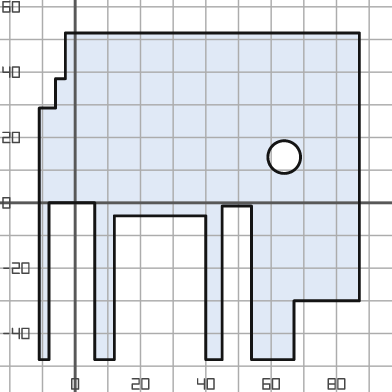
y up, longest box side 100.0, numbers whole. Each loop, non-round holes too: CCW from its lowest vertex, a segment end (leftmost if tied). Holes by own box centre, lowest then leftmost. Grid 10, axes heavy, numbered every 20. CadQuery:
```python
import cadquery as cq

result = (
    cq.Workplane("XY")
    .moveTo(-11.0, -48.0)
    .lineTo(-8.0, -48.0)
    .lineTo(-8.0, 0.0)
    .lineTo(6.0, 0.0)
    .lineTo(6.0, -48.0)
    .lineTo(12.0, -48.0)
    .lineTo(12.0, -4.0)
    .lineTo(40.0, -4.0)
    .lineTo(40.0, -48.0)
    .lineTo(45.0, -48.0)
    .lineTo(45.0, -1.0)
    .lineTo(54.0, -1.0)
    .lineTo(54.0, -48.0)
    .lineTo(67.0, -48.0)
    .lineTo(67.0, -30.0)
    .lineTo(87.0, -30.0)
    .lineTo(87.0, 52.0)
    .lineTo(-3.0, 52.0)
    .lineTo(-3.0, 38.0)
    .lineTo(-6.0, 38.0)
    .lineTo(-6.0, 29.0)
    .lineTo(-11.0, 29.0)
    .close()
    .moveTo(64.0, 14.0)
    .circle(5.0)
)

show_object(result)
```